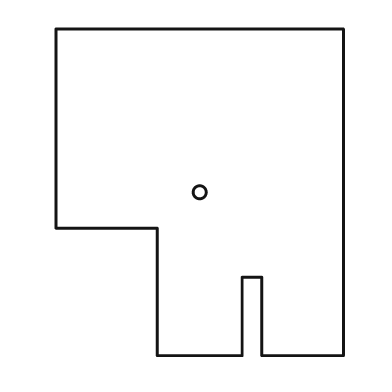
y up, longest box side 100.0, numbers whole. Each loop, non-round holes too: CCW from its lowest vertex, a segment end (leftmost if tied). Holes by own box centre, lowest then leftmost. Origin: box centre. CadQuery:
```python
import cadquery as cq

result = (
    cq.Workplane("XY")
    .moveTo(-13.0, -50.0)
    .lineTo(13.0, -50.0)
    .lineTo(13.0, -26.0)
    .lineTo(19.0, -26.0)
    .lineTo(19.0, -50.0)
    .lineTo(44.0, -50.0)
    .lineTo(44.0, 50.0)
    .lineTo(-44.0, 50.0)
    .lineTo(-44.0, -11.0)
    .lineTo(-13.0, -11.0)
    .close()
    .moveTo(0.0, 0.0)
    .circle(2.0)
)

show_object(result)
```